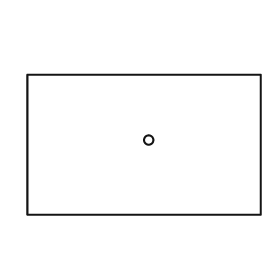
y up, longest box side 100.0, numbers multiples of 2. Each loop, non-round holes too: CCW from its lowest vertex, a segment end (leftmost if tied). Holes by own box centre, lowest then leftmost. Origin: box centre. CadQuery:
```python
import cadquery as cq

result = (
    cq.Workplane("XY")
    .moveTo(-50.0, -30.0)
    .lineTo(50.0, -30.0)
    .lineTo(50.0, 30.0)
    .lineTo(-50.0, 30.0)
    .close()
    .moveTo(2.0, 2.0)
    .circle(2.0)
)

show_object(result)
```